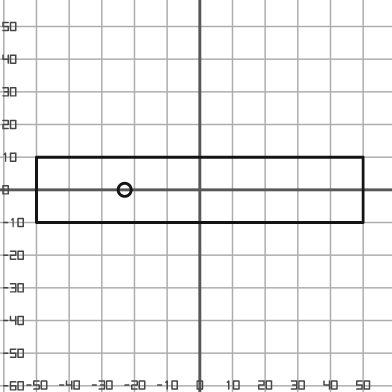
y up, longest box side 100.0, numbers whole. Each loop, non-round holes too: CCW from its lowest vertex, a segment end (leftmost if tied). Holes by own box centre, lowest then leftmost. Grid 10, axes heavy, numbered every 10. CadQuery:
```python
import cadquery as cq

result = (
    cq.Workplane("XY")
    .moveTo(-50.0, -10.0)
    .lineTo(50.0, -10.0)
    .lineTo(50.0, 10.0)
    .lineTo(-50.0, 10.0)
    .close()
    .moveTo(-23.0, 0.0)
    .circle(2.0)
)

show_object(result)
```